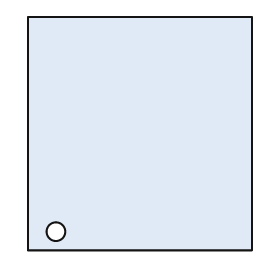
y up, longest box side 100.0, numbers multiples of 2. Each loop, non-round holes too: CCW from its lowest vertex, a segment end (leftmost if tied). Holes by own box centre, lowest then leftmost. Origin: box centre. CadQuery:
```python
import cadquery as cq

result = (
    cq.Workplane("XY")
    .moveTo(-48.0, -50.0)
    .lineTo(48.0, -50.0)
    .lineTo(48.0, 50.0)
    .lineTo(-48.0, 50.0)
    .close()
    .moveTo(-36.0, -42.0)
    .circle(4.0)
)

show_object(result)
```